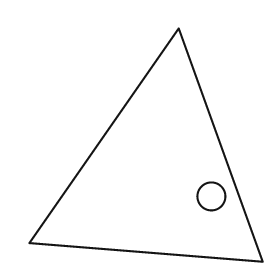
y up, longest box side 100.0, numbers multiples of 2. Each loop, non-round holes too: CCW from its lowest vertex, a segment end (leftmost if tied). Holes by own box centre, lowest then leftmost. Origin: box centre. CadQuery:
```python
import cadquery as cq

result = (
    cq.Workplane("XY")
    .moveTo(50.0, -50.0)
    .lineTo(14.0, 50.0)
    .lineTo(-50.0, -42.0)
    .close()
    .moveTo(28.0, -22.0)
    .circle(6.0)
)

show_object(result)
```